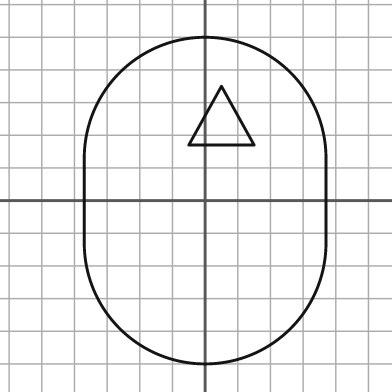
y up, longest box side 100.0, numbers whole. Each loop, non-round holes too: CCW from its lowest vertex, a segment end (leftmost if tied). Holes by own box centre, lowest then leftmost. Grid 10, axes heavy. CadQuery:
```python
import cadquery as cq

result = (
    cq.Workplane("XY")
    .moveTo(-37.0, -13.0)
    .threePointArc((0.0, -50.0), (37.0, -13.0))
    .lineTo(37.0, 13.0)
    .threePointArc((0.0, 50.0), (-37.0, 13.0))
    .close()
    .moveTo(-5.0, 17.0)
    .lineTo(15.0, 17.0)
    .lineTo(5.0, 35.0)
    .close()
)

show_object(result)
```